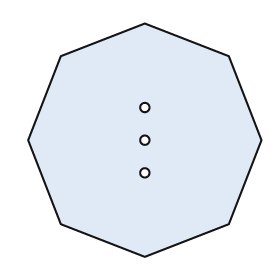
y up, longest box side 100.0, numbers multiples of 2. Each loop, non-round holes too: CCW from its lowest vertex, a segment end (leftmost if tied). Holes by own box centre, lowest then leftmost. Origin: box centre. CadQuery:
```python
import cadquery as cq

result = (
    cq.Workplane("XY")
    .moveTo(0.0, -50.0)
    .lineTo(36.0, -36.0)
    .lineTo(50.0, 0.0)
    .lineTo(36.0, 36.0)
    .lineTo(0.0, 50.0)
    .lineTo(-36.0, 36.0)
    .lineTo(-50.0, 0.0)
    .lineTo(-36.0, -36.0)
    .close()
    .moveTo(0.0, -14.0)
    .circle(2.0)
    .moveTo(0.0, 0.0)
    .circle(2.0)
    .moveTo(0.0, 14.0)
    .circle(2.0)
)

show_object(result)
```